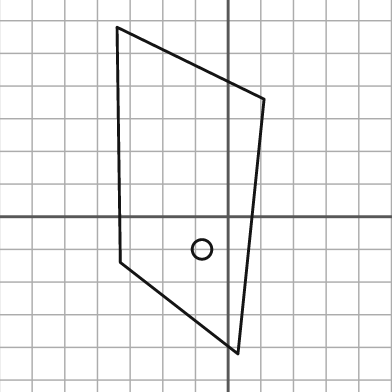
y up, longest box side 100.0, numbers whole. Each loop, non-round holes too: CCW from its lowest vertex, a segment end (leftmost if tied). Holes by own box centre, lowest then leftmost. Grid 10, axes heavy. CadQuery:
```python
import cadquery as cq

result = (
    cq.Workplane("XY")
    .moveTo(3.0, -42.0)
    .lineTo(11.0, 36.0)
    .lineTo(-34.0, 58.0)
    .lineTo(-33.0, -14.0)
    .close()
    .moveTo(-8.0, -10.0)
    .circle(3.0)
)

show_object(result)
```